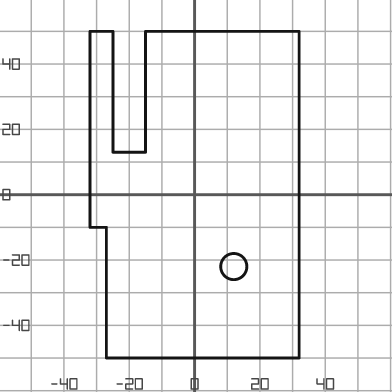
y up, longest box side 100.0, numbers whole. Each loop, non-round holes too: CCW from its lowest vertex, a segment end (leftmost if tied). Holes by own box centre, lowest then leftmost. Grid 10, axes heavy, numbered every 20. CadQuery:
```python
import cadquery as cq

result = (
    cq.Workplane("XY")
    .moveTo(-27.0, -50.0)
    .lineTo(32.0, -50.0)
    .lineTo(32.0, 50.0)
    .lineTo(-15.0, 50.0)
    .lineTo(-15.0, 13.0)
    .lineTo(-25.0, 13.0)
    .lineTo(-25.0, 50.0)
    .lineTo(-32.0, 50.0)
    .lineTo(-32.0, -10.0)
    .lineTo(-27.0, -10.0)
    .close()
    .moveTo(12.0, -22.0)
    .circle(4.0)
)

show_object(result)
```